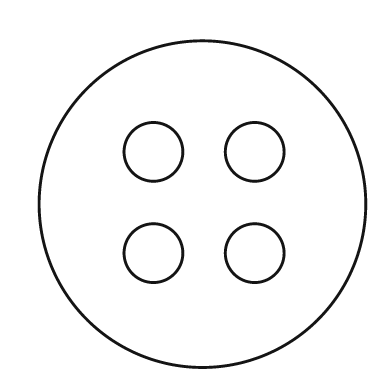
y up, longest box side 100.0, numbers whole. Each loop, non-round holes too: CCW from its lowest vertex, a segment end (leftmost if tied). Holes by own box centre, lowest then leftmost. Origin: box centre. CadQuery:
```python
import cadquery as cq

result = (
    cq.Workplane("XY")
    .moveTo(0.0, 0.0)
    .circle(50.0)
    .moveTo(-15.0, -15.0)
    .circle(9.0)
    .moveTo(16.0, -15.0)
    .circle(9.0)
    .moveTo(-15.0, 16.0)
    .circle(9.0)
    .moveTo(16.0, 16.0)
    .circle(9.0)
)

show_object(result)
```